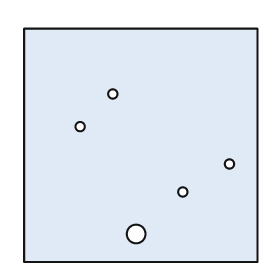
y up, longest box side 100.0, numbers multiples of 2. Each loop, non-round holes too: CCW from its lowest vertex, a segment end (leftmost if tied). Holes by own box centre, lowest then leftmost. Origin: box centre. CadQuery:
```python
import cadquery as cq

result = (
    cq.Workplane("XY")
    .moveTo(-50.0, -50.0)
    .lineTo(50.0, -50.0)
    .lineTo(50.0, 50.0)
    .lineTo(-50.0, 50.0)
    .close()
    .moveTo(-2.0, -38.0)
    .circle(4.0)
    .moveTo(18.0, -20.0)
    .circle(2.0)
    .moveTo(38.0, -8.0)
    .circle(2.0)
    .moveTo(-26.0, 8.0)
    .circle(2.0)
    .moveTo(-12.0, 22.0)
    .circle(2.0)
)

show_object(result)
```